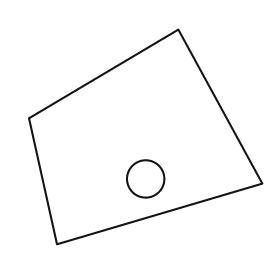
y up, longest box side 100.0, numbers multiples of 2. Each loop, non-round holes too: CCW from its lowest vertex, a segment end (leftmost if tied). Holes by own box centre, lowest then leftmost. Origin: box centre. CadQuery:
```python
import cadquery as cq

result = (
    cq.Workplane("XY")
    .moveTo(-38.0, -46.0)
    .lineTo(50.0, -20.0)
    .lineTo(14.0, 46.0)
    .lineTo(-50.0, 8.0)
    .close()
    .moveTo(0.0, -18.0)
    .circle(8.0)
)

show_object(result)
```